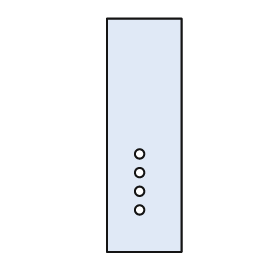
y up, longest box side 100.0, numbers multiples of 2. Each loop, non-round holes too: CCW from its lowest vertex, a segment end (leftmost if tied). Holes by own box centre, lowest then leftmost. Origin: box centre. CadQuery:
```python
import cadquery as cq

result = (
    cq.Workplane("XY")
    .moveTo(-16.0, -50.0)
    .lineTo(16.0, -50.0)
    .lineTo(16.0, 50.0)
    .lineTo(-16.0, 50.0)
    .close()
    .moveTo(-2.0, -32.0)
    .circle(2.0)
    .moveTo(-2.0, -24.0)
    .circle(2.0)
    .moveTo(-2.0, -16.0)
    .circle(2.0)
    .moveTo(-2.0, -8.0)
    .circle(2.0)
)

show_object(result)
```